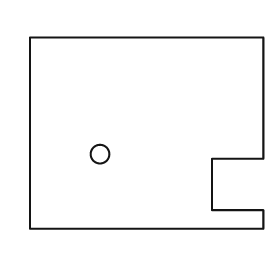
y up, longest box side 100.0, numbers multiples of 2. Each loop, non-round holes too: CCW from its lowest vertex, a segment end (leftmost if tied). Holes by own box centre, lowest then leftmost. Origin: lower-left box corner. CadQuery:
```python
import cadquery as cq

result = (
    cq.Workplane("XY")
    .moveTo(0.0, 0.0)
    .lineTo(100.0, 0.0)
    .lineTo(100.0, 8.0)
    .lineTo(78.0, 8.0)
    .lineTo(78.0, 30.0)
    .lineTo(100.0, 30.0)
    .lineTo(100.0, 82.0)
    .lineTo(0.0, 82.0)
    .close()
    .moveTo(30.0, 32.0)
    .circle(4.0)
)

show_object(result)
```